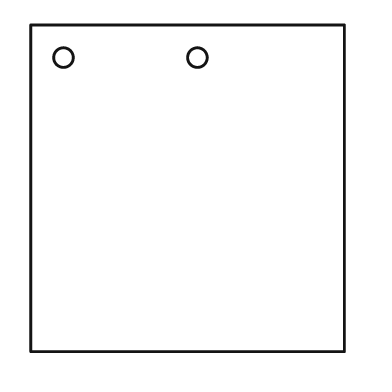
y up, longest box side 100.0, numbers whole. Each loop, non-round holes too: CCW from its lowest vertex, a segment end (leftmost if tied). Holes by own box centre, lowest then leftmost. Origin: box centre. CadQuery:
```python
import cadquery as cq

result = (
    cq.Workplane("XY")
    .moveTo(-48.0, -50.0)
    .lineTo(48.0, -50.0)
    .lineTo(48.0, 50.0)
    .lineTo(-48.0, 50.0)
    .close()
    .moveTo(-38.0, 40.0)
    .circle(3.0)
    .moveTo(3.0, 40.0)
    .circle(3.0)
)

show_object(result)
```